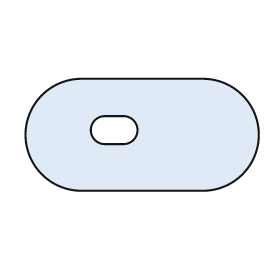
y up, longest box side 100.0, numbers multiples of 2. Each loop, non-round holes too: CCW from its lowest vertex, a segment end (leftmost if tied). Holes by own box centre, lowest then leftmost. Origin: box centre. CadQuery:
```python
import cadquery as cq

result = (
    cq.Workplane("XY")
    .moveTo(-26.0, -24.0)
    .lineTo(26.0, -24.0)
    .threePointArc((50.0, 0.0), (26.0, 24.0))
    .lineTo(-26.0, 24.0)
    .threePointArc((-50.0, 0.0), (-26.0, -24.0))
    .close()
    .moveTo(-16.0, -4.0)
    .lineTo(-8.0, -4.0)
    .threePointArc((-2.0, 2.0), (-8.0, 8.0))
    .lineTo(-16.0, 8.0)
    .threePointArc((-22.0, 2.0), (-16.0, -4.0))
    .close()
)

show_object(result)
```